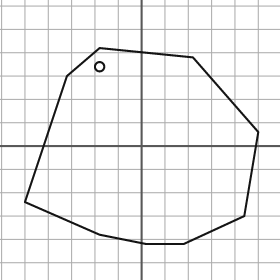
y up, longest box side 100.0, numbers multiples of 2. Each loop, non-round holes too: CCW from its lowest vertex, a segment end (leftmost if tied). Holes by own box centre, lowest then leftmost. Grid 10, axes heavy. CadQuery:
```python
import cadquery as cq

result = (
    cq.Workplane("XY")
    .moveTo(2.0, -42.0)
    .lineTo(18.0, -42.0)
    .lineTo(44.0, -30.0)
    .lineTo(50.0, 6.0)
    .lineTo(22.0, 38.0)
    .lineTo(-18.0, 42.0)
    .lineTo(-32.0, 30.0)
    .lineTo(-50.0, -24.0)
    .lineTo(-18.0, -38.0)
    .close()
    .moveTo(-18.0, 34.0)
    .circle(2.0)
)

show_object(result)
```